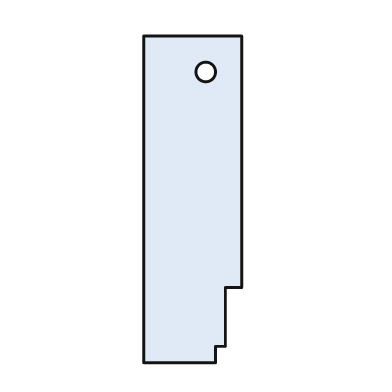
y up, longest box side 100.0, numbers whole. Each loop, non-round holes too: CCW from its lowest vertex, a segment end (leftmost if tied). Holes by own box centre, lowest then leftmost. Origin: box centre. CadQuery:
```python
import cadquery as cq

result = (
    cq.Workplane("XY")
    .moveTo(-15.0, -50.0)
    .lineTo(7.0, -50.0)
    .lineTo(7.0, -45.0)
    .lineTo(10.0, -45.0)
    .lineTo(10.0, -27.0)
    .lineTo(15.0, -27.0)
    .lineTo(15.0, 50.0)
    .lineTo(-15.0, 50.0)
    .close()
    .moveTo(4.0, 39.0)
    .circle(3.0)
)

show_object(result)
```